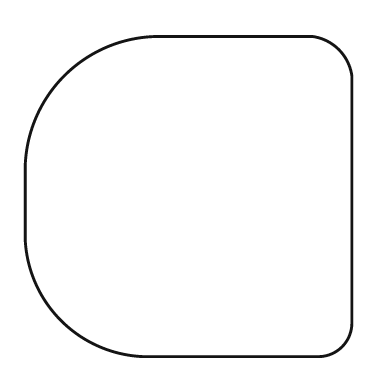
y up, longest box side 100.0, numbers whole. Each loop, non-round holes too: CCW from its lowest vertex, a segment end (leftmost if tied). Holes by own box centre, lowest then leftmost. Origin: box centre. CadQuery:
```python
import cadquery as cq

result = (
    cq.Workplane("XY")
    .moveTo(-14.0, -49.0)
    .lineTo(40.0, -49.0)
    .threePointArc((47.0, -46.0), (50.0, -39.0))
    .lineTo(50.0, 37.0)
    .threePointArc((46.0, 45.0), (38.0, 49.0))
    .lineTo(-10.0, 49.0)
    .threePointArc((-38.0, 37.0), (-50.0, 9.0))
    .lineTo(-50.0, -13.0)
    .threePointArc((-39.0, -38.0), (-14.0, -49.0))
    .close()
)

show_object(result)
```